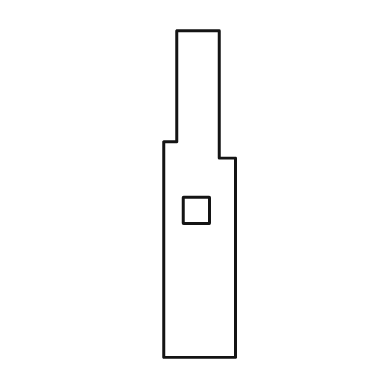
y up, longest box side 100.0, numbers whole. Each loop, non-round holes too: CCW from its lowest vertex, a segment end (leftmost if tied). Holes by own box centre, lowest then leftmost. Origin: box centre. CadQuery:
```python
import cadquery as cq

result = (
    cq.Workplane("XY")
    .moveTo(-11.0, -50.0)
    .lineTo(11.0, -50.0)
    .lineTo(11.0, 11.0)
    .lineTo(6.0, 11.0)
    .lineTo(6.0, 50.0)
    .lineTo(-7.0, 50.0)
    .lineTo(-7.0, 16.0)
    .lineTo(-11.0, 16.0)
    .close()
    .moveTo(-5.0, -9.0)
    .lineTo(3.0, -9.0)
    .lineTo(3.0, -1.0)
    .lineTo(-5.0, -1.0)
    .close()
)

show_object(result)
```